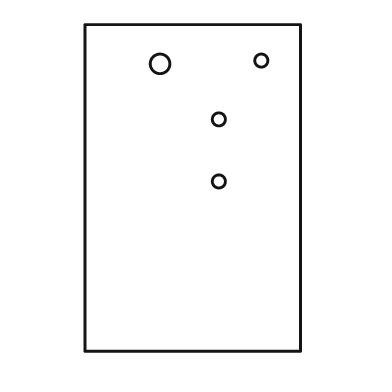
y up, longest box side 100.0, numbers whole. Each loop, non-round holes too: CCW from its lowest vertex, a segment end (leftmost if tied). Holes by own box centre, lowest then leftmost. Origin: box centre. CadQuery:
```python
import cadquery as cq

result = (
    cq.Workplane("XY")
    .moveTo(-33.0, -50.0)
    .lineTo(33.0, -50.0)
    .lineTo(33.0, 50.0)
    .lineTo(-33.0, 50.0)
    .close()
    .moveTo(8.0, 2.0)
    .circle(2.0)
    .moveTo(8.0, 21.0)
    .circle(2.0)
    .moveTo(-10.0, 38.0)
    .circle(3.0)
    .moveTo(21.0, 39.0)
    .circle(2.0)
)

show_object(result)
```